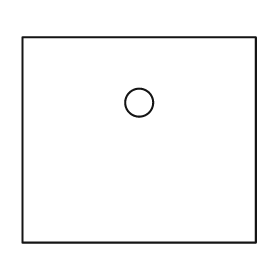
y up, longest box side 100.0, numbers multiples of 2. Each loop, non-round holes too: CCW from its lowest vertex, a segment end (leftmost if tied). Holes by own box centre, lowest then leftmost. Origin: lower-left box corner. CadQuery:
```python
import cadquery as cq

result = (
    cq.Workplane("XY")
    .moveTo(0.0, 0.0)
    .lineTo(100.0, 0.0)
    .lineTo(100.0, 88.0)
    .lineTo(0.0, 88.0)
    .close()
    .moveTo(50.0, 60.0)
    .circle(6.0)
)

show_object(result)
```